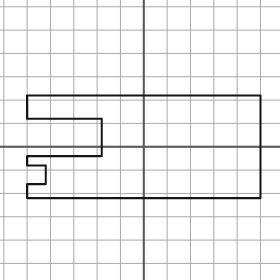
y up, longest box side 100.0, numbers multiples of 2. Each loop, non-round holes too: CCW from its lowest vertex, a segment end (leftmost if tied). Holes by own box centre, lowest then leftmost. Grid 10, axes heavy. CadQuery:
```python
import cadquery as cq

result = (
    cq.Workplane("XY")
    .moveTo(-50.0, -22.0)
    .lineTo(50.0, -22.0)
    .lineTo(50.0, 22.0)
    .lineTo(-50.0, 22.0)
    .lineTo(-50.0, 12.0)
    .lineTo(-18.0, 12.0)
    .lineTo(-18.0, -4.0)
    .lineTo(-50.0, -4.0)
    .lineTo(-50.0, -8.0)
    .lineTo(-42.0, -8.0)
    .lineTo(-42.0, -16.0)
    .lineTo(-50.0, -16.0)
    .close()
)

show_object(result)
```